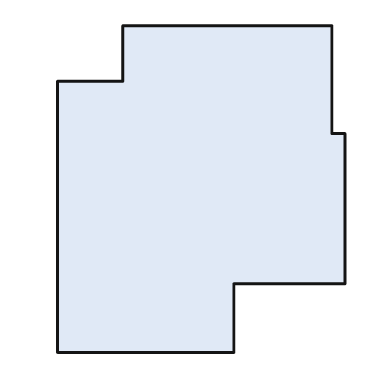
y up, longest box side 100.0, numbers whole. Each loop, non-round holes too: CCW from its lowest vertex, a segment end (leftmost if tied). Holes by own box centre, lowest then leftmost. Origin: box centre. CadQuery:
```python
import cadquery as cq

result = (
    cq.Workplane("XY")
    .moveTo(-44.0, -50.0)
    .lineTo(10.0, -50.0)
    .lineTo(10.0, -29.0)
    .lineTo(44.0, -29.0)
    .lineTo(44.0, 17.0)
    .lineTo(40.0, 17.0)
    .lineTo(40.0, 50.0)
    .lineTo(-24.0, 50.0)
    .lineTo(-24.0, 33.0)
    .lineTo(-44.0, 33.0)
    .close()
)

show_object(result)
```